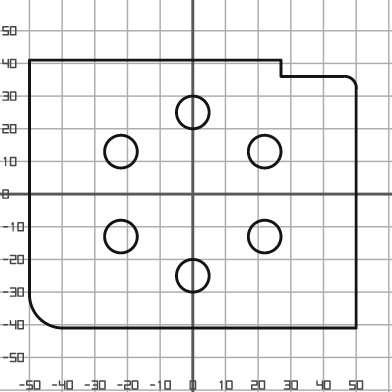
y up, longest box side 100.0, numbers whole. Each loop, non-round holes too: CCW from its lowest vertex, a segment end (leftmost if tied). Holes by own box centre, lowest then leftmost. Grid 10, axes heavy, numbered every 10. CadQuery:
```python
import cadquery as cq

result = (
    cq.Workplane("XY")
    .moveTo(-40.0, -41.0)
    .lineTo(50.0, -41.0)
    .lineTo(50.0, 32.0)
    .threePointArc((49.0, 35.0), (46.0, 36.0))
    .lineTo(27.0, 36.0)
    .lineTo(27.0, 41.0)
    .lineTo(-50.0, 41.0)
    .lineTo(-50.0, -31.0)
    .threePointArc((-47.0, -38.0), (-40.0, -41.0))
    .close()
    .moveTo(0.0, -25.0)
    .circle(5.0)
    .moveTo(-22.0, -13.0)
    .circle(5.0)
    .moveTo(22.0, -13.0)
    .circle(5.0)
    .moveTo(-22.0, 13.0)
    .circle(5.0)
    .moveTo(22.0, 13.0)
    .circle(5.0)
    .moveTo(0.0, 25.0)
    .circle(5.0)
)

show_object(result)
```